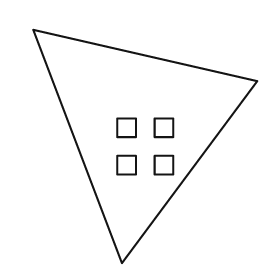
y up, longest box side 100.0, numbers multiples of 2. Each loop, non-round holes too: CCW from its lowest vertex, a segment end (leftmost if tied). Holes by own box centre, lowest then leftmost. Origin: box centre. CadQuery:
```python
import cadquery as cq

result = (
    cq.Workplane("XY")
    .moveTo(-10.0, -50.0)
    .lineTo(48.0, 28.0)
    .lineTo(-48.0, 50.0)
    .close()
    .moveTo(-12.0, -12.0)
    .lineTo(-4.0, -12.0)
    .lineTo(-4.0, -4.0)
    .lineTo(-12.0, -4.0)
    .close()
    .moveTo(4.0, -12.0)
    .lineTo(12.0, -12.0)
    .lineTo(12.0, -4.0)
    .lineTo(4.0, -4.0)
    .close()
    .moveTo(-12.0, 4.0)
    .lineTo(-4.0, 4.0)
    .lineTo(-4.0, 12.0)
    .lineTo(-12.0, 12.0)
    .close()
    .moveTo(4.0, 4.0)
    .lineTo(12.0, 4.0)
    .lineTo(12.0, 12.0)
    .lineTo(4.0, 12.0)
    .close()
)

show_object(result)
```